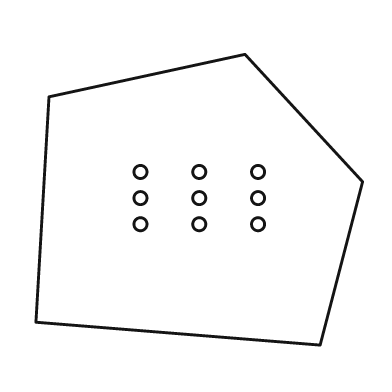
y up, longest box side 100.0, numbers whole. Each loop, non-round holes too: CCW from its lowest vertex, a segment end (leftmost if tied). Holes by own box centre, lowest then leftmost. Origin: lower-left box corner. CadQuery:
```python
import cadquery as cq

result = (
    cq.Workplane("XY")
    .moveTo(87.0, 0.0)
    .lineTo(100.0, 50.0)
    .lineTo(64.0, 89.0)
    .lineTo(4.0, 76.0)
    .lineTo(0.0, 7.0)
    .close()
    .moveTo(32.0, 37.0)
    .circle(2.0)
    .moveTo(50.0, 37.0)
    .circle(2.0)
    .moveTo(68.0, 37.0)
    .circle(2.0)
    .moveTo(32.0, 45.0)
    .circle(2.0)
    .moveTo(50.0, 45.0)
    .circle(2.0)
    .moveTo(68.0, 45.0)
    .circle(2.0)
    .moveTo(32.0, 53.0)
    .circle(2.0)
    .moveTo(50.0, 53.0)
    .circle(2.0)
    .moveTo(68.0, 53.0)
    .circle(2.0)
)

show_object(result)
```